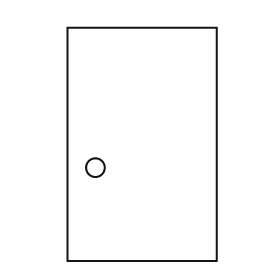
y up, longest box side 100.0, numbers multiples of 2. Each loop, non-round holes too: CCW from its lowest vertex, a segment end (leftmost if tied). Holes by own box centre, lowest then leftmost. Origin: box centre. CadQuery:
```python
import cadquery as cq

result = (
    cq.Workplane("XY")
    .moveTo(-32.0, -50.0)
    .lineTo(32.0, -50.0)
    .lineTo(32.0, 50.0)
    .lineTo(-32.0, 50.0)
    .close()
    .moveTo(-20.0, -10.0)
    .circle(4.0)
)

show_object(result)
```